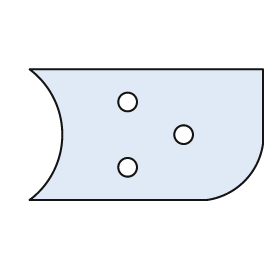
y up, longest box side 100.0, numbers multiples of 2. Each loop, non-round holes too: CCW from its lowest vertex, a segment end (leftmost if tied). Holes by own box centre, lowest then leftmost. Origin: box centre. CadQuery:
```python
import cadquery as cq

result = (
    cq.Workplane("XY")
    .moveTo(-50.0, -28.0)
    .lineTo(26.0, -28.0)
    .threePointArc((42.0, -20.0), (50.0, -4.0))
    .lineTo(50.0, 28.0)
    .lineTo(-50.0, 28.0)
    .threePointArc((-36.0, 0.0), (-50.0, -28.0))
    .close()
    .moveTo(-8.0, -14.0)
    .circle(4.0)
    .moveTo(16.0, 0.0)
    .circle(4.0)
    .moveTo(-8.0, 14.0)
    .circle(4.0)
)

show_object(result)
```